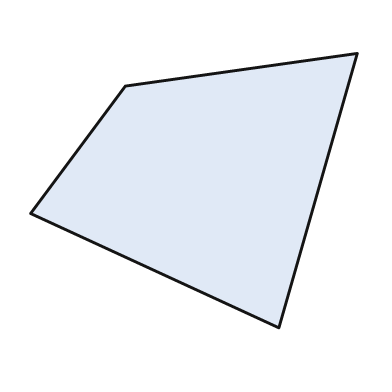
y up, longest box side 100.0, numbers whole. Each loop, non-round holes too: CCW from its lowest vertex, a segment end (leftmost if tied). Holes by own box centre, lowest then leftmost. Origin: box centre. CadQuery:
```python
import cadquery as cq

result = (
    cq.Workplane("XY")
    .moveTo(26.0, -42.0)
    .lineTo(50.0, 42.0)
    .lineTo(-21.0, 32.0)
    .lineTo(-50.0, -7.0)
    .close()
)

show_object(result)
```